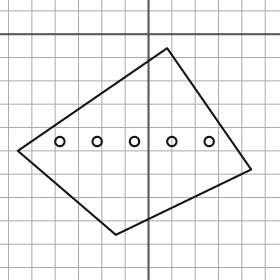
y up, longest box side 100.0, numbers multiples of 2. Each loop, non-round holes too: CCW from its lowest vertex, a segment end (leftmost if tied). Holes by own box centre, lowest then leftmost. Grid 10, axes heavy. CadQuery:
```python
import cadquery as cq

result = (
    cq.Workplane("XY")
    .moveTo(-14.0, -86.0)
    .lineTo(44.0, -58.0)
    .lineTo(8.0, -6.0)
    .lineTo(-56.0, -50.0)
    .close()
    .moveTo(-38.0, -46.0)
    .circle(2.0)
    .moveTo(-22.0, -46.0)
    .circle(2.0)
    .moveTo(-6.0, -46.0)
    .circle(2.0)
    .moveTo(10.0, -46.0)
    .circle(2.0)
    .moveTo(26.0, -46.0)
    .circle(2.0)
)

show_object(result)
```